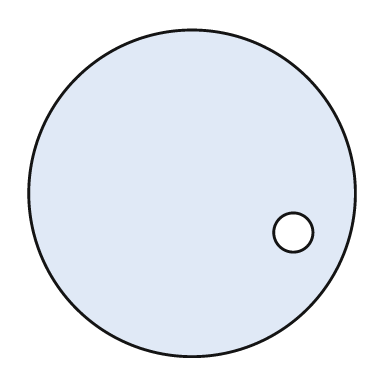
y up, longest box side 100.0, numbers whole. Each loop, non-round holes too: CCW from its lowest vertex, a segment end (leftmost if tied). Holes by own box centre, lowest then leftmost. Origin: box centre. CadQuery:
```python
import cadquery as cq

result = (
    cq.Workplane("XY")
    .moveTo(0.0, 0.0)
    .circle(50.0)
    .moveTo(31.0, -12.0)
    .circle(6.0)
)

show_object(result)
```